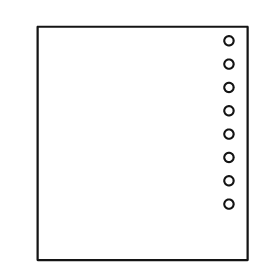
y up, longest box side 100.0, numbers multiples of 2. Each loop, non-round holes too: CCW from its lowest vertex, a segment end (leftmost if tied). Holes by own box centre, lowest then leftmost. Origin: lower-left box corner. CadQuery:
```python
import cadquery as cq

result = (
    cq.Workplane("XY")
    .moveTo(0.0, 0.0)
    .lineTo(90.0, 0.0)
    .lineTo(90.0, 100.0)
    .lineTo(0.0, 100.0)
    .close()
    .moveTo(82.0, 24.0)
    .circle(2.0)
    .moveTo(82.0, 34.0)
    .circle(2.0)
    .moveTo(82.0, 44.0)
    .circle(2.0)
    .moveTo(82.0, 54.0)
    .circle(2.0)
    .moveTo(82.0, 64.0)
    .circle(2.0)
    .moveTo(82.0, 74.0)
    .circle(2.0)
    .moveTo(82.0, 84.0)
    .circle(2.0)
    .moveTo(82.0, 94.0)
    .circle(2.0)
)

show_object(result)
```